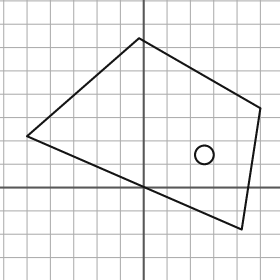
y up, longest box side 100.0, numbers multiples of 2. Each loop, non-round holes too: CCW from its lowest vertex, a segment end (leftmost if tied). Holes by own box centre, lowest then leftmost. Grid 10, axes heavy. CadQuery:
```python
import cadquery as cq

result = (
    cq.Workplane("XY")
    .moveTo(42.0, -18.0)
    .lineTo(50.0, 34.0)
    .lineTo(-2.0, 64.0)
    .lineTo(-50.0, 22.0)
    .close()
    .moveTo(26.0, 14.0)
    .circle(4.0)
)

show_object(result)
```